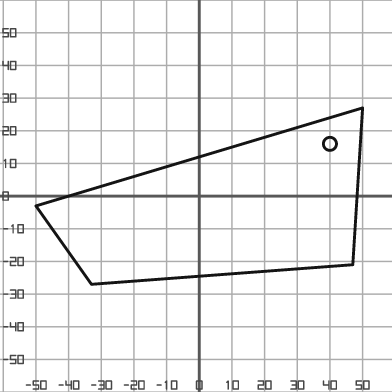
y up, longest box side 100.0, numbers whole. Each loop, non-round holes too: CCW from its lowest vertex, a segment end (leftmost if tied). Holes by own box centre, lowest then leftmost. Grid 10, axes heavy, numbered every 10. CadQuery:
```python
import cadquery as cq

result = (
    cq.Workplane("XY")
    .moveTo(-33.0, -27.0)
    .lineTo(47.0, -21.0)
    .lineTo(50.0, 27.0)
    .lineTo(-50.0, -3.0)
    .close()
    .moveTo(40.0, 16.0)
    .circle(2.0)
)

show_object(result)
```